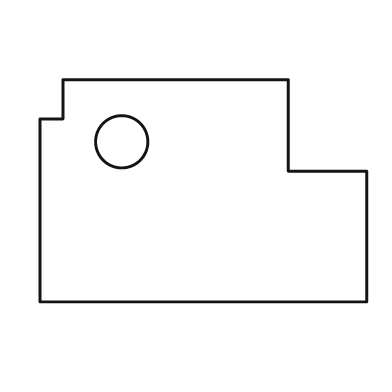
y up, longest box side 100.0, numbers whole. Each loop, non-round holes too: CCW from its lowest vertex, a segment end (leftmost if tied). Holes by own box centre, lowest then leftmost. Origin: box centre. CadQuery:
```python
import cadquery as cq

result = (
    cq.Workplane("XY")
    .moveTo(-50.0, -34.0)
    .lineTo(50.0, -34.0)
    .lineTo(50.0, 6.0)
    .lineTo(26.0, 6.0)
    .lineTo(26.0, 34.0)
    .lineTo(-43.0, 34.0)
    .lineTo(-43.0, 22.0)
    .lineTo(-50.0, 22.0)
    .close()
    .moveTo(-25.0, 15.0)
    .circle(8.0)
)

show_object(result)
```